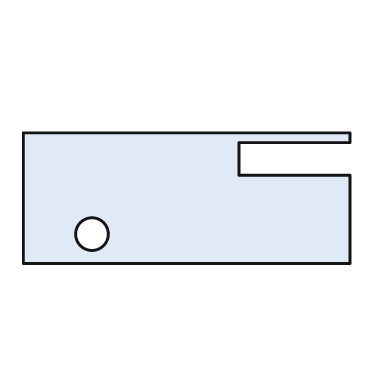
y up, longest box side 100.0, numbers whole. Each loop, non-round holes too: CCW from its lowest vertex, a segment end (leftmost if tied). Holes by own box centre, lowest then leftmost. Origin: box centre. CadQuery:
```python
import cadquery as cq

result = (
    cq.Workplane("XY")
    .moveTo(-50.0, -20.0)
    .lineTo(50.0, -20.0)
    .lineTo(50.0, 7.0)
    .lineTo(16.0, 7.0)
    .lineTo(16.0, 17.0)
    .lineTo(50.0, 17.0)
    .lineTo(50.0, 20.0)
    .lineTo(-50.0, 20.0)
    .close()
    .moveTo(-29.0, -11.0)
    .circle(5.0)
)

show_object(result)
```